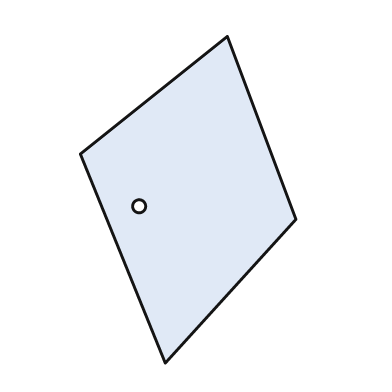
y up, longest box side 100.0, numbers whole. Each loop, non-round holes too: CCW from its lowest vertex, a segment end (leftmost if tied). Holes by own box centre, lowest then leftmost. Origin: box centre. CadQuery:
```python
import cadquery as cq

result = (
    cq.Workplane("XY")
    .moveTo(-7.0, -50.0)
    .lineTo(33.0, -6.0)
    .lineTo(12.0, 50.0)
    .lineTo(-33.0, 14.0)
    .close()
    .moveTo(-15.0, -2.0)
    .circle(2.0)
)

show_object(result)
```